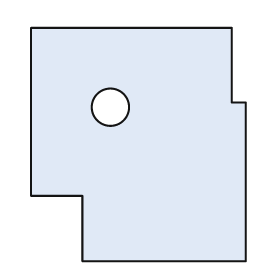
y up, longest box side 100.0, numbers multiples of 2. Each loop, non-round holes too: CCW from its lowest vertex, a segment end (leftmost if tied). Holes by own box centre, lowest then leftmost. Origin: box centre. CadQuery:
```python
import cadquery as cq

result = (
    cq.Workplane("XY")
    .moveTo(-24.0, -50.0)
    .lineTo(46.0, -50.0)
    .lineTo(46.0, 18.0)
    .lineTo(40.0, 18.0)
    .lineTo(40.0, 50.0)
    .lineTo(-46.0, 50.0)
    .lineTo(-46.0, -22.0)
    .lineTo(-24.0, -22.0)
    .close()
    .moveTo(-12.0, 16.0)
    .circle(8.0)
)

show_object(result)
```